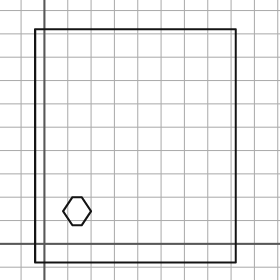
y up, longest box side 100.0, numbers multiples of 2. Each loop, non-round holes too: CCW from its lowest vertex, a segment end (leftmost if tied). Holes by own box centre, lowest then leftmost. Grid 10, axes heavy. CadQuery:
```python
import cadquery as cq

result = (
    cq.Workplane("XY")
    .moveTo(-4.0, -8.0)
    .lineTo(82.0, -8.0)
    .lineTo(82.0, 92.0)
    .lineTo(-4.0, 92.0)
    .close()
    .moveTo(12.0, 8.0)
    .lineTo(16.0, 8.0)
    .lineTo(20.0, 14.0)
    .lineTo(16.0, 20.0)
    .lineTo(12.0, 20.0)
    .lineTo(8.0, 14.0)
    .close()
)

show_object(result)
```